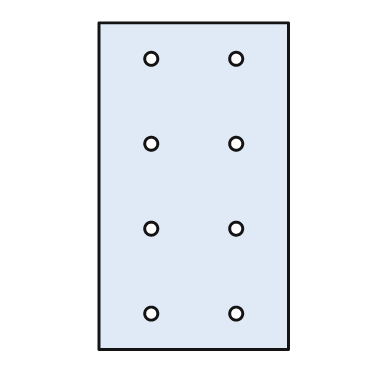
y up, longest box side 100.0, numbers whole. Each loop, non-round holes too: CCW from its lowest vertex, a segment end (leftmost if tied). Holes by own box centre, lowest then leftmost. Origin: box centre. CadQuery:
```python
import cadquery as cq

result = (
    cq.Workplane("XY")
    .moveTo(-29.0, -50.0)
    .lineTo(29.0, -50.0)
    .lineTo(29.0, 50.0)
    .lineTo(-29.0, 50.0)
    .close()
    .moveTo(-13.0, -39.0)
    .circle(2.0)
    .moveTo(13.0, -39.0)
    .circle(2.0)
    .moveTo(-13.0, -13.0)
    .circle(2.0)
    .moveTo(13.0, -13.0)
    .circle(2.0)
    .moveTo(-13.0, 13.0)
    .circle(2.0)
    .moveTo(13.0, 13.0)
    .circle(2.0)
    .moveTo(-13.0, 39.0)
    .circle(2.0)
    .moveTo(13.0, 39.0)
    .circle(2.0)
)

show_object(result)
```